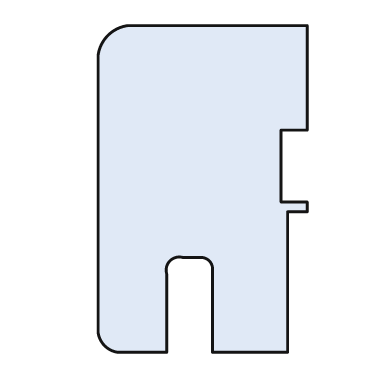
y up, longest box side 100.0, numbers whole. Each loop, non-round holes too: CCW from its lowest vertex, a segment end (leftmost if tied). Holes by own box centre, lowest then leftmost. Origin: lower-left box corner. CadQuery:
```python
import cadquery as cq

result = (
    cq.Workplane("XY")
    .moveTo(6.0, 0.0)
    .lineTo(21.0, 0.0)
    .lineTo(21.0, 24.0)
    .threePointArc((22.0, 28.0), (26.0, 29.0))
    .lineTo(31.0, 29.0)
    .threePointArc((34.0, 28.0), (35.0, 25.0))
    .lineTo(35.0, 0.0)
    .lineTo(58.0, 0.0)
    .lineTo(58.0, 43.0)
    .lineTo(64.0, 43.0)
    .lineTo(64.0, 46.0)
    .lineTo(56.0, 46.0)
    .lineTo(56.0, 68.0)
    .lineTo(64.0, 68.0)
    .lineTo(64.0, 100.0)
    .lineTo(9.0, 100.0)
    .threePointArc((3.0, 97.0), (0.0, 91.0))
    .lineTo(0.0, 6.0)
    .threePointArc((2.0, 2.0), (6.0, 0.0))
    .close()
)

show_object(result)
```